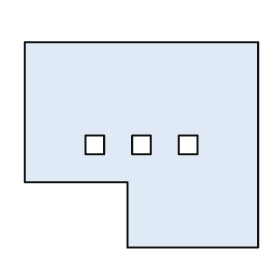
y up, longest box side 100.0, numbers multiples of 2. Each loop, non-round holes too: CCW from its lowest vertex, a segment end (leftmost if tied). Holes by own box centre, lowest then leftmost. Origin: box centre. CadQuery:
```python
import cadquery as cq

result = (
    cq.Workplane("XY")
    .moveTo(-6.0, -44.0)
    .lineTo(50.0, -44.0)
    .lineTo(50.0, 44.0)
    .lineTo(-50.0, 44.0)
    .lineTo(-50.0, -16.0)
    .lineTo(-6.0, -16.0)
    .close()
    .moveTo(-24.0, -4.0)
    .lineTo(-16.0, -4.0)
    .lineTo(-16.0, 4.0)
    .lineTo(-24.0, 4.0)
    .close()
    .moveTo(-4.0, -4.0)
    .lineTo(4.0, -4.0)
    .lineTo(4.0, 4.0)
    .lineTo(-4.0, 4.0)
    .close()
    .moveTo(16.0, -4.0)
    .lineTo(24.0, -4.0)
    .lineTo(24.0, 4.0)
    .lineTo(16.0, 4.0)
    .close()
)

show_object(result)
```